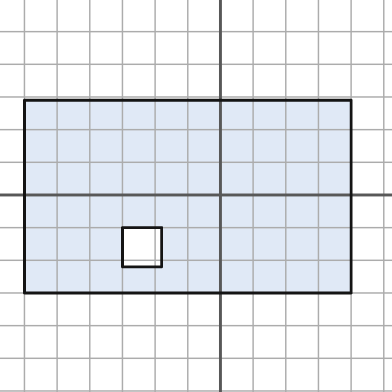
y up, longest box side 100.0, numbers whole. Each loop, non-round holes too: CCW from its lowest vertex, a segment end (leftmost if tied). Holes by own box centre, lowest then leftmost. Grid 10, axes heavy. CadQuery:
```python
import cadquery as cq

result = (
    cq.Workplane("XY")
    .moveTo(-60.0, -30.0)
    .lineTo(40.0, -30.0)
    .lineTo(40.0, 29.0)
    .lineTo(-60.0, 29.0)
    .close()
    .moveTo(-30.0, -22.0)
    .lineTo(-18.0, -22.0)
    .lineTo(-18.0, -10.0)
    .lineTo(-30.0, -10.0)
    .close()
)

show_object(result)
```